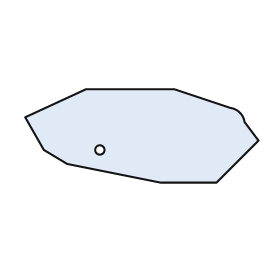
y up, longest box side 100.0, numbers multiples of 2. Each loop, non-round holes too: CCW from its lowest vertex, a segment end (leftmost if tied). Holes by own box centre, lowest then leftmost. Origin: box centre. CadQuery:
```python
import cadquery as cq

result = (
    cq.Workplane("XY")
    .moveTo(8.0, -20.0)
    .lineTo(32.0, -20.0)
    .lineTo(50.0, -2.0)
    .lineTo(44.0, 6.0)
    .threePointArc((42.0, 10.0), (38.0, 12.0))
    .lineTo(14.0, 20.0)
    .lineTo(-24.0, 20.0)
    .lineTo(-50.0, 8.0)
    .lineTo(-42.0, -6.0)
    .lineTo(-32.0, -12.0)
    .close()
    .moveTo(-18.0, -6.0)
    .circle(2.0)
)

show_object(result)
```